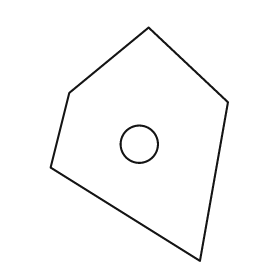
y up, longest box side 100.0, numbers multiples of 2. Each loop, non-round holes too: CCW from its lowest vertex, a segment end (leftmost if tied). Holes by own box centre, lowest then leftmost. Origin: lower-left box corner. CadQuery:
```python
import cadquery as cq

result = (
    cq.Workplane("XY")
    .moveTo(64.0, 0.0)
    .lineTo(76.0, 68.0)
    .lineTo(42.0, 100.0)
    .lineTo(8.0, 72.0)
    .lineTo(0.0, 40.0)
    .close()
    .moveTo(38.0, 50.0)
    .circle(8.0)
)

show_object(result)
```